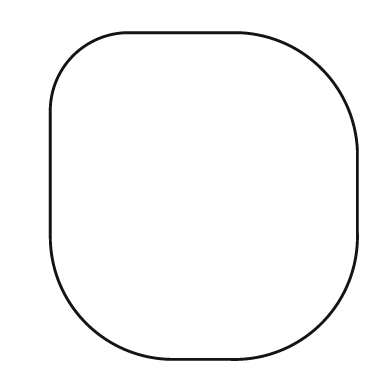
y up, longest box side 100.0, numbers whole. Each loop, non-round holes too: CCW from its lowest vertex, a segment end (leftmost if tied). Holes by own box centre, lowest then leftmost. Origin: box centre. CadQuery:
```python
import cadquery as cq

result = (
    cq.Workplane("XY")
    .moveTo(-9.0, -50.0)
    .lineTo(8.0, -50.0)
    .threePointArc((36.0, -39.0), (47.0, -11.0))
    .lineTo(47.0, 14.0)
    .threePointArc((36.0, 39.0), (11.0, 50.0))
    .lineTo(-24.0, 50.0)
    .threePointArc((-40.0, 43.0), (-47.0, 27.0))
    .lineTo(-47.0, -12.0)
    .threePointArc((-36.0, -39.0), (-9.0, -50.0))
    .close()
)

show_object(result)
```